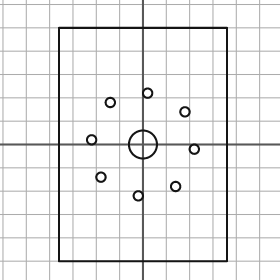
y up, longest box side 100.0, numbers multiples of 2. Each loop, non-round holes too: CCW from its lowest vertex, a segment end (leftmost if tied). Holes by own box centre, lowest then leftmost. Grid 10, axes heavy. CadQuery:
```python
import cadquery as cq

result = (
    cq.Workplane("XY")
    .moveTo(-36.0, -50.0)
    .lineTo(36.0, -50.0)
    .lineTo(36.0, 50.0)
    .lineTo(-36.0, 50.0)
    .close()
    .moveTo(-2.0, -22.0)
    .circle(2.0)
    .moveTo(14.0, -18.0)
    .circle(2.0)
    .moveTo(-18.0, -14.0)
    .circle(2.0)
    .moveTo(22.0, -2.0)
    .circle(2.0)
    .moveTo(0.0, 0.0)
    .circle(6.0)
    .moveTo(-22.0, 2.0)
    .circle(2.0)
    .moveTo(18.0, 14.0)
    .circle(2.0)
    .moveTo(-14.0, 18.0)
    .circle(2.0)
    .moveTo(2.0, 22.0)
    .circle(2.0)
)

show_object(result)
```